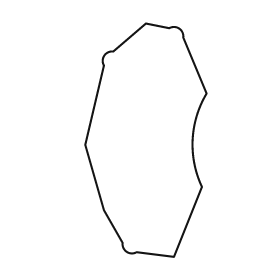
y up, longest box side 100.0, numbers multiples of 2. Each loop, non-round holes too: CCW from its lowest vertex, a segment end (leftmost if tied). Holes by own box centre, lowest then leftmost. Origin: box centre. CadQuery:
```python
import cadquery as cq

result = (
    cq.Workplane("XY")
    .moveTo(12.0, -50.0)
    .lineTo(24.0, -20.0)
    .threePointArc((20.0, 0.0), (26.0, 20.0))
    .lineTo(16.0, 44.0)
    .threePointArc((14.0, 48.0), (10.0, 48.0))
    .lineTo(0.0, 50.0)
    .lineTo(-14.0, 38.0)
    .threePointArc((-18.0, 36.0), (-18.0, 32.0))
    .lineTo(-26.0, -2.0)
    .lineTo(-18.0, -30.0)
    .lineTo(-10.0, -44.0)
    .threePointArc((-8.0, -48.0), (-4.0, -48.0))
    .close()
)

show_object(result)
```